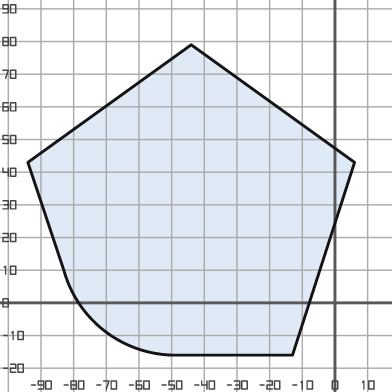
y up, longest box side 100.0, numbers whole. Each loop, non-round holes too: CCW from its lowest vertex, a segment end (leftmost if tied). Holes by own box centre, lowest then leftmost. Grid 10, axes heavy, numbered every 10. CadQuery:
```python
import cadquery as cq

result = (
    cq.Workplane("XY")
    .moveTo(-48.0, -16.0)
    .lineTo(-13.0, -16.0)
    .lineTo(6.0, 43.0)
    .lineTo(-44.0, 79.0)
    .lineTo(-94.0, 43.0)
    .lineTo(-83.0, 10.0)
    .threePointArc((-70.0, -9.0), (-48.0, -16.0))
    .close()
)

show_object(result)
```